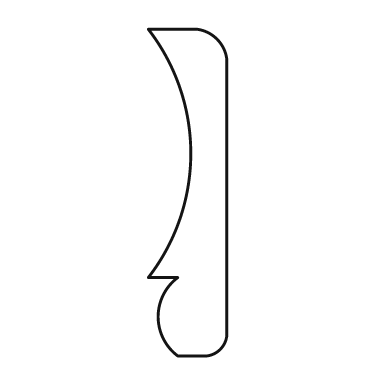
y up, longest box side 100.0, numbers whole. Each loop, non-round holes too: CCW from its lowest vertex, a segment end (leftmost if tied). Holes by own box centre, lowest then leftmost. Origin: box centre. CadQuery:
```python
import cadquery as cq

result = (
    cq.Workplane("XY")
    .moveTo(-3.0, -50.0)
    .lineTo(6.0, -50.0)
    .threePointArc((10.0, -48.0), (12.0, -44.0))
    .lineTo(12.0, 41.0)
    .threePointArc((9.0, 47.0), (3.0, 50.0))
    .lineTo(-12.0, 50.0)
    .threePointArc((1.0, 12.0), (-12.0, -26.0))
    .lineTo(-3.0, -26.0)
    .threePointArc((-9.0, -38.0), (-3.0, -50.0))
    .close()
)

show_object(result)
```